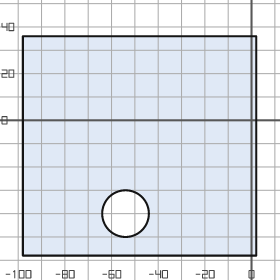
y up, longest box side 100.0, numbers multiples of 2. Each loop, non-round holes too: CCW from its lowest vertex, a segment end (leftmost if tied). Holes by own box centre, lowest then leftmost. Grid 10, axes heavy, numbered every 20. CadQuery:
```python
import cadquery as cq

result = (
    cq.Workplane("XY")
    .moveTo(-98.0, -58.0)
    .lineTo(2.0, -58.0)
    .lineTo(2.0, 36.0)
    .lineTo(-98.0, 36.0)
    .close()
    .moveTo(-54.0, -40.0)
    .circle(10.0)
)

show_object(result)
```